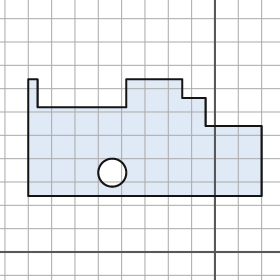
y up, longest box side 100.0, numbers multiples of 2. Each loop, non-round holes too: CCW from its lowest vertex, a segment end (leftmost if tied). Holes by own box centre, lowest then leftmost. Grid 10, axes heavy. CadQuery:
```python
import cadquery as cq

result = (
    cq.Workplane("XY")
    .moveTo(-80.0, 24.0)
    .lineTo(20.0, 24.0)
    .lineTo(20.0, 54.0)
    .lineTo(-4.0, 54.0)
    .lineTo(-4.0, 66.0)
    .lineTo(-14.0, 66.0)
    .lineTo(-14.0, 74.0)
    .lineTo(-38.0, 74.0)
    .lineTo(-38.0, 62.0)
    .lineTo(-76.0, 62.0)
    .lineTo(-76.0, 74.0)
    .lineTo(-80.0, 74.0)
    .close()
    .moveTo(-44.0, 34.0)
    .circle(6.0)
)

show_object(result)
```